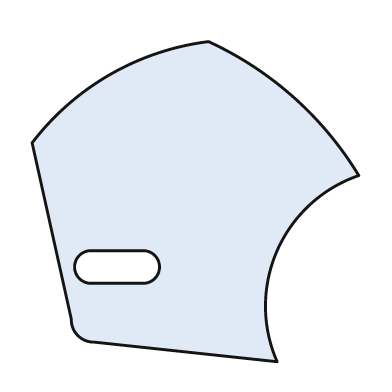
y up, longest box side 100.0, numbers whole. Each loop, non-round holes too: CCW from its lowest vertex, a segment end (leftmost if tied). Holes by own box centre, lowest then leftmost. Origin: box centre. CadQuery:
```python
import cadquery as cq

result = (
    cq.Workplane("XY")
    .moveTo(25.0, -49.0)
    .threePointArc((25.0, -15.0), (50.0, 8.0))
    .threePointArc((30.0, 32.0), (4.0, 49.0))
    .threePointArc((-26.0, 39.0), (-50.0, 18.0))
    .lineTo(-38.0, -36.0)
    .threePointArc((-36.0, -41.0), (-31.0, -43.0))
    .close()
    .moveTo(-32.0, -25.0)
    .lineTo(-16.0, -25.0)
    .threePointArc((-11.0, -20.0), (-16.0, -15.0))
    .lineTo(-32.0, -15.0)
    .threePointArc((-37.0, -20.0), (-32.0, -25.0))
    .close()
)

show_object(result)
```